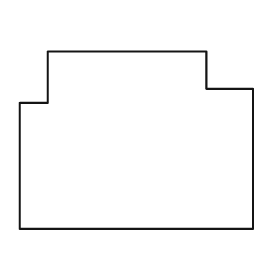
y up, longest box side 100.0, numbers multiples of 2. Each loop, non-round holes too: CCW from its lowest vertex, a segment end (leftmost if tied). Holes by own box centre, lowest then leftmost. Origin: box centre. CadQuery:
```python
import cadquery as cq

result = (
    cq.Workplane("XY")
    .moveTo(-50.0, -38.0)
    .lineTo(50.0, -38.0)
    .lineTo(50.0, 22.0)
    .lineTo(30.0, 22.0)
    .lineTo(30.0, 38.0)
    .lineTo(-38.0, 38.0)
    .lineTo(-38.0, 16.0)
    .lineTo(-50.0, 16.0)
    .close()
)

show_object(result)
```